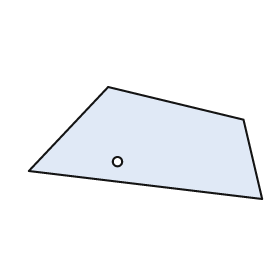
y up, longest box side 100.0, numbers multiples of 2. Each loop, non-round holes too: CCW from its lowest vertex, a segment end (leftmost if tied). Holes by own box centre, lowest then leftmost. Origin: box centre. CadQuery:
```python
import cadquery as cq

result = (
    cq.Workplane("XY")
    .moveTo(50.0, -24.0)
    .lineTo(42.0, 10.0)
    .lineTo(-16.0, 24.0)
    .lineTo(-50.0, -12.0)
    .close()
    .moveTo(-12.0, -8.0)
    .circle(2.0)
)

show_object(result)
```